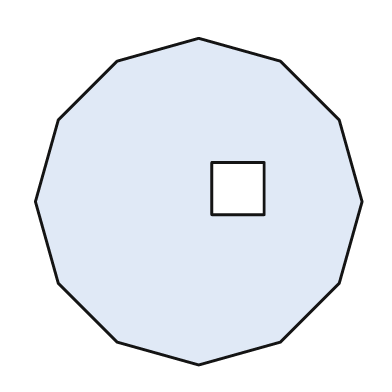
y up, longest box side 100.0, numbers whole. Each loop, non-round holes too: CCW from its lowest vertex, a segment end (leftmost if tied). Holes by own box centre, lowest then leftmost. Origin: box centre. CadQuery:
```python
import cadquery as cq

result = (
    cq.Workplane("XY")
    .moveTo(0.0, -50.0)
    .lineTo(25.0, -43.0)
    .lineTo(43.0, -25.0)
    .lineTo(50.0, 0.0)
    .lineTo(43.0, 25.0)
    .lineTo(25.0, 43.0)
    .lineTo(0.0, 50.0)
    .lineTo(-25.0, 43.0)
    .lineTo(-43.0, 25.0)
    .lineTo(-50.0, 0.0)
    .lineTo(-43.0, -25.0)
    .lineTo(-25.0, -43.0)
    .close()
    .moveTo(4.0, -4.0)
    .lineTo(20.0, -4.0)
    .lineTo(20.0, 12.0)
    .lineTo(4.0, 12.0)
    .close()
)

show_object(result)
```